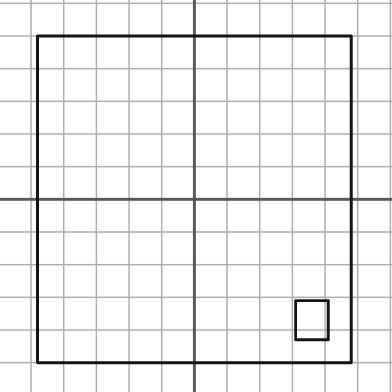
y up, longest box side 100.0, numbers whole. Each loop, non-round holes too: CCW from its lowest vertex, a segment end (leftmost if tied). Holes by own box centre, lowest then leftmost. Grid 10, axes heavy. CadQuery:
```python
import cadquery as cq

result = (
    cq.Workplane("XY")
    .moveTo(-48.0, -50.0)
    .lineTo(48.0, -50.0)
    .lineTo(48.0, 50.0)
    .lineTo(-48.0, 50.0)
    .close()
    .moveTo(31.0, -43.0)
    .lineTo(41.0, -43.0)
    .lineTo(41.0, -31.0)
    .lineTo(31.0, -31.0)
    .close()
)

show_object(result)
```